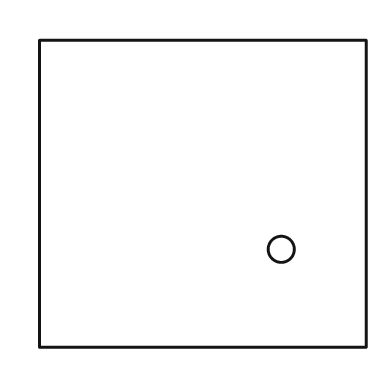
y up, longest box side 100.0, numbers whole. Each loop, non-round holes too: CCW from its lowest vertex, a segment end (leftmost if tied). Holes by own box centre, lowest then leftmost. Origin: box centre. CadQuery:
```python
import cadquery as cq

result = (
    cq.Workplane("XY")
    .moveTo(-50.0, -47.0)
    .lineTo(50.0, -47.0)
    .lineTo(50.0, 47.0)
    .lineTo(-50.0, 47.0)
    .close()
    .moveTo(24.0, -17.0)
    .circle(4.0)
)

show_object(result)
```